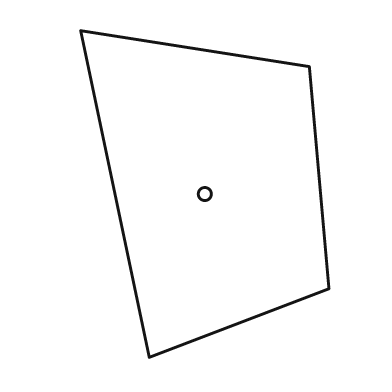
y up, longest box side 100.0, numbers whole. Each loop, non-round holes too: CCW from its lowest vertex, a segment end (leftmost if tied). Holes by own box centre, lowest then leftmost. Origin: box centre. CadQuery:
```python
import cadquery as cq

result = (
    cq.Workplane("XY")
    .moveTo(-17.0, -50.0)
    .lineTo(38.0, -29.0)
    .lineTo(32.0, 39.0)
    .lineTo(-38.0, 50.0)
    .close()
    .moveTo(0.0, 0.0)
    .circle(2.0)
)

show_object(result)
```